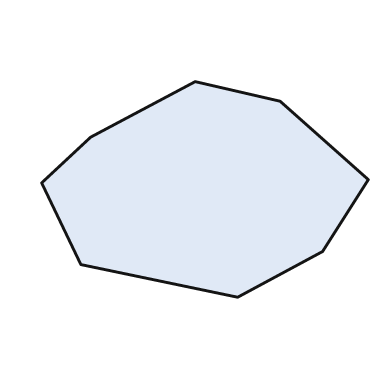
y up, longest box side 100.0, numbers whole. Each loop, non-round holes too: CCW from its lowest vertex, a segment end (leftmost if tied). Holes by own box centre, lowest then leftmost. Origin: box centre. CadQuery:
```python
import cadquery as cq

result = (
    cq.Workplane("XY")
    .moveTo(10.0, -33.0)
    .lineTo(36.0, -19.0)
    .lineTo(50.0, 3.0)
    .lineTo(23.0, 27.0)
    .lineTo(-3.0, 33.0)
    .lineTo(-35.0, 16.0)
    .lineTo(-50.0, 2.0)
    .lineTo(-38.0, -23.0)
    .close()
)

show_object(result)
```